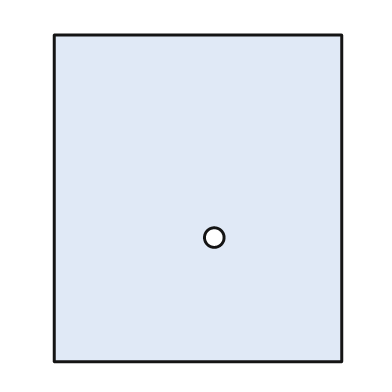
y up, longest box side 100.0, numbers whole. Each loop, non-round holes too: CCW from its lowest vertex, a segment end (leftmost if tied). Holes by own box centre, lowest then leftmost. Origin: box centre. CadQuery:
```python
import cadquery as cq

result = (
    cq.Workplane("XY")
    .moveTo(-44.0, -50.0)
    .lineTo(44.0, -50.0)
    .lineTo(44.0, 50.0)
    .lineTo(-44.0, 50.0)
    .close()
    .moveTo(5.0, -12.0)
    .circle(3.0)
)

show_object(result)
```